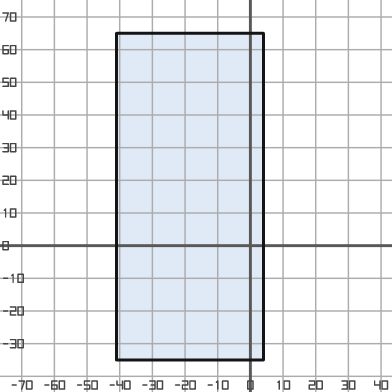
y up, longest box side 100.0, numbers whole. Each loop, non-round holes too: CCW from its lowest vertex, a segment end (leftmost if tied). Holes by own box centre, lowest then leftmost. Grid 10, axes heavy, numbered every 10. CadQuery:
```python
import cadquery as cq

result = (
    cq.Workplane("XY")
    .moveTo(-41.0, -35.0)
    .lineTo(4.0, -35.0)
    .lineTo(4.0, 65.0)
    .lineTo(-41.0, 65.0)
    .close()
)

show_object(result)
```